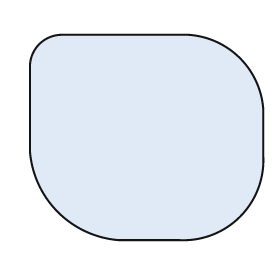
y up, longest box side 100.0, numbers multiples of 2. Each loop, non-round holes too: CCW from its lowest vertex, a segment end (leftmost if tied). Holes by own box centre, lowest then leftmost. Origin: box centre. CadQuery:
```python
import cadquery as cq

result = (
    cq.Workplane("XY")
    .moveTo(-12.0, -44.0)
    .lineTo(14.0, -44.0)
    .threePointArc((40.0, -34.0), (50.0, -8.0))
    .lineTo(50.0, 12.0)
    .threePointArc((40.0, 34.0), (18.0, 44.0))
    .lineTo(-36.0, 44.0)
    .threePointArc((-46.0, 40.0), (-50.0, 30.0))
    .lineTo(-50.0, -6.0)
    .threePointArc((-38.0, -32.0), (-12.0, -44.0))
    .close()
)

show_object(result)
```